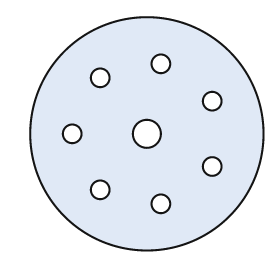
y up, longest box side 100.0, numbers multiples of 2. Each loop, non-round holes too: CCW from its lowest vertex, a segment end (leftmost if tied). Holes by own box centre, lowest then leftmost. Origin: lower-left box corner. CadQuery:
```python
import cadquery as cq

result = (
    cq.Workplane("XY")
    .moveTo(50.0, 50.0)
    .circle(50.0)
    .moveTo(56.0, 20.0)
    .circle(4.0)
    .moveTo(30.0, 26.0)
    .circle(4.0)
    .moveTo(78.0, 36.0)
    .circle(4.0)
    .moveTo(18.0, 50.0)
    .circle(4.0)
    .moveTo(50.0, 50.0)
    .circle(6.0)
    .moveTo(78.0, 64.0)
    .circle(4.0)
    .moveTo(30.0, 74.0)
    .circle(4.0)
    .moveTo(56.0, 80.0)
    .circle(4.0)
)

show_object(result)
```